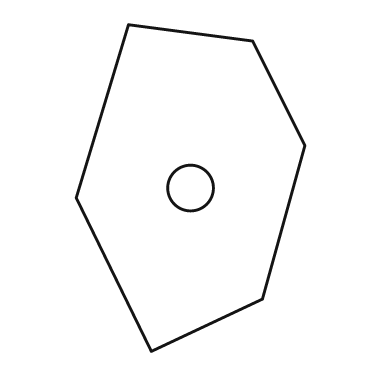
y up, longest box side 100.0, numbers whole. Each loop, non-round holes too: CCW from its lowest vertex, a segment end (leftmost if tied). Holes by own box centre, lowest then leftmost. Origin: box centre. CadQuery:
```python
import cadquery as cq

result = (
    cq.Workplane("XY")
    .moveTo(-12.0, -50.0)
    .lineTo(22.0, -34.0)
    .lineTo(35.0, 13.0)
    .lineTo(19.0, 45.0)
    .lineTo(-19.0, 50.0)
    .lineTo(-35.0, -3.0)
    .close()
    .moveTo(0.0, 0.0)
    .circle(7.0)
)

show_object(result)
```